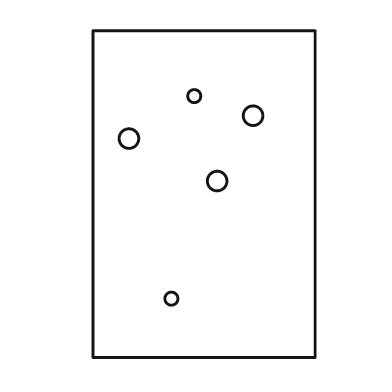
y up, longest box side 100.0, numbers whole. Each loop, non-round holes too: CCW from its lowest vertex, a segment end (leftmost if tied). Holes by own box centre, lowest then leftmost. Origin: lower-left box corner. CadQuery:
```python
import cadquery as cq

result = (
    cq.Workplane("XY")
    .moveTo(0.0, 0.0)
    .lineTo(68.0, 0.0)
    .lineTo(68.0, 100.0)
    .lineTo(0.0, 100.0)
    .close()
    .moveTo(24.0, 18.0)
    .circle(2.0)
    .moveTo(38.0, 54.0)
    .circle(3.0)
    .moveTo(11.0, 67.0)
    .circle(3.0)
    .moveTo(49.0, 74.0)
    .circle(3.0)
    .moveTo(31.0, 80.0)
    .circle(2.0)
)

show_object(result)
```